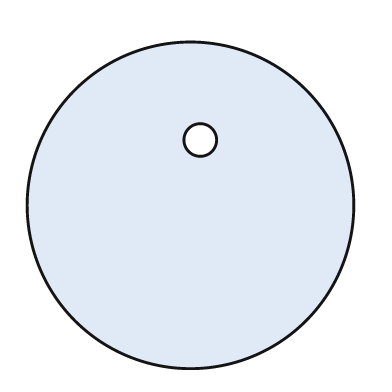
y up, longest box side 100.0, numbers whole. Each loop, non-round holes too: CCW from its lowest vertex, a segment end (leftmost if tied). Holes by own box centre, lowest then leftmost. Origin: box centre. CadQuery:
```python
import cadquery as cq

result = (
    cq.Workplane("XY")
    .moveTo(0.0, 0.0)
    .circle(50.0)
    .moveTo(3.0, 20.0)
    .circle(5.0)
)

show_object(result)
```